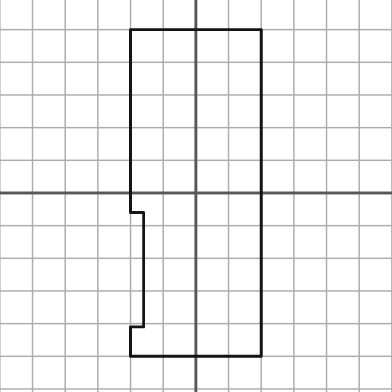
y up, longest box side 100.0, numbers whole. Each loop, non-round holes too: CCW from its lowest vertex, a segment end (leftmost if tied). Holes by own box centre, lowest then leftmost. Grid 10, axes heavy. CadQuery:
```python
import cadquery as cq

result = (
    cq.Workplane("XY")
    .moveTo(-20.0, -50.0)
    .lineTo(20.0, -50.0)
    .lineTo(20.0, 50.0)
    .lineTo(-20.0, 50.0)
    .lineTo(-20.0, -6.0)
    .lineTo(-16.0, -6.0)
    .lineTo(-16.0, -41.0)
    .lineTo(-20.0, -41.0)
    .close()
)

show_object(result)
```